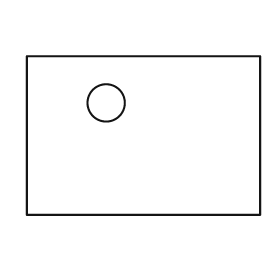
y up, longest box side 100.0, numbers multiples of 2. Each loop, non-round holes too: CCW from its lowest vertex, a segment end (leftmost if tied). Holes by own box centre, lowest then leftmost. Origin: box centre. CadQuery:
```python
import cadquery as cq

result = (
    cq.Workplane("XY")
    .moveTo(-50.0, -34.0)
    .lineTo(50.0, -34.0)
    .lineTo(50.0, 34.0)
    .lineTo(-50.0, 34.0)
    .close()
    .moveTo(-16.0, 14.0)
    .circle(8.0)
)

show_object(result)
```